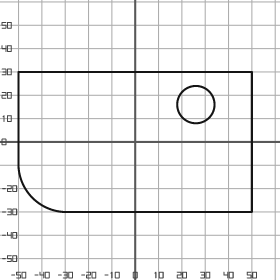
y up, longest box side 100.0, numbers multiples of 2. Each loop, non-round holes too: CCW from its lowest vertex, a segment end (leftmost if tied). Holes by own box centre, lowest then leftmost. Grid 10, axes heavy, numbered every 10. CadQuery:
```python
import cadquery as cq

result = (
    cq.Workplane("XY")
    .moveTo(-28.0, -30.0)
    .lineTo(50.0, -30.0)
    .lineTo(50.0, 30.0)
    .lineTo(-50.0, 30.0)
    .lineTo(-50.0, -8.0)
    .threePointArc((-44.0, -24.0), (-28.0, -30.0))
    .close()
    .moveTo(26.0, 16.0)
    .circle(8.0)
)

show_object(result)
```